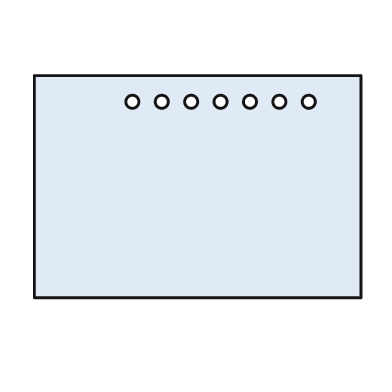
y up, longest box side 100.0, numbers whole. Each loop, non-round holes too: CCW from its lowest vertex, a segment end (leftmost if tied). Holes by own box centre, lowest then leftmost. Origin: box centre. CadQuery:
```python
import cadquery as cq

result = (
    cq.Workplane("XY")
    .moveTo(-50.0, -34.0)
    .lineTo(50.0, -34.0)
    .lineTo(50.0, 34.0)
    .lineTo(-50.0, 34.0)
    .close()
    .moveTo(-20.0, 26.0)
    .circle(2.0)
    .moveTo(-11.0, 26.0)
    .circle(2.0)
    .moveTo(-2.0, 26.0)
    .circle(2.0)
    .moveTo(7.0, 26.0)
    .circle(2.0)
    .moveTo(16.0, 26.0)
    .circle(2.0)
    .moveTo(25.0, 26.0)
    .circle(2.0)
    .moveTo(34.0, 26.0)
    .circle(2.0)
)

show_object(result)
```